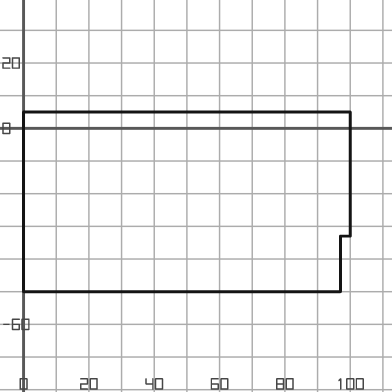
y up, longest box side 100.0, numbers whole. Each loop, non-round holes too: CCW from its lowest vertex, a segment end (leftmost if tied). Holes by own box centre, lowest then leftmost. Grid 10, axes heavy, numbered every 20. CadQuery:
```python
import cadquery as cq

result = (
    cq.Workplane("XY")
    .moveTo(0.0, -50.0)
    .lineTo(97.0, -50.0)
    .lineTo(97.0, -33.0)
    .lineTo(100.0, -33.0)
    .lineTo(100.0, 5.0)
    .lineTo(0.0, 5.0)
    .close()
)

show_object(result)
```